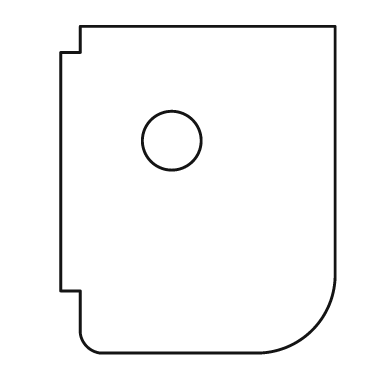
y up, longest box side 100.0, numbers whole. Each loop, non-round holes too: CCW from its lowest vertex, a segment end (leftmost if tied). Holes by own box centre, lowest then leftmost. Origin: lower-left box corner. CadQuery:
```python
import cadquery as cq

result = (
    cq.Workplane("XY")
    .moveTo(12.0, 0.0)
    .lineTo(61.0, 0.0)
    .threePointArc((77.0, 7.0), (84.0, 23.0))
    .lineTo(84.0, 100.0)
    .lineTo(6.0, 100.0)
    .lineTo(6.0, 92.0)
    .lineTo(0.0, 92.0)
    .lineTo(0.0, 19.0)
    .lineTo(6.0, 19.0)
    .lineTo(6.0, 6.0)
    .threePointArc((8.0, 2.0), (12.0, 0.0))
    .close()
    .moveTo(34.0, 65.0)
    .circle(9.0)
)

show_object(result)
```